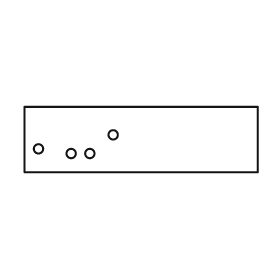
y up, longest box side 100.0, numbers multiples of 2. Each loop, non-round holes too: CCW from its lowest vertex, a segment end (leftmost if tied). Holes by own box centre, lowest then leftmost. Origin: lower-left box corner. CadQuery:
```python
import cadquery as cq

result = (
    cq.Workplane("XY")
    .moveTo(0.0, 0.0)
    .lineTo(100.0, 0.0)
    .lineTo(100.0, 28.0)
    .lineTo(0.0, 28.0)
    .close()
    .moveTo(20.0, 8.0)
    .circle(2.0)
    .moveTo(28.0, 8.0)
    .circle(2.0)
    .moveTo(6.0, 10.0)
    .circle(2.0)
    .moveTo(38.0, 16.0)
    .circle(2.0)
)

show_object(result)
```